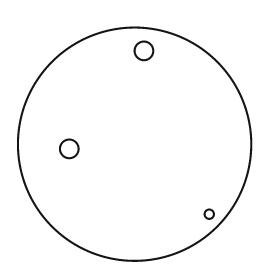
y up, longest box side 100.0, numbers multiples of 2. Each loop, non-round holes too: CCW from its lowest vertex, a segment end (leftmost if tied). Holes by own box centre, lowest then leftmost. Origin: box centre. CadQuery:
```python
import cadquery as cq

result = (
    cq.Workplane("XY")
    .moveTo(0.0, 0.0)
    .circle(50.0)
    .moveTo(32.0, -30.0)
    .circle(2.0)
    .moveTo(-28.0, -2.0)
    .circle(4.0)
    .moveTo(4.0, 40.0)
    .circle(4.0)
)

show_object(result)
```